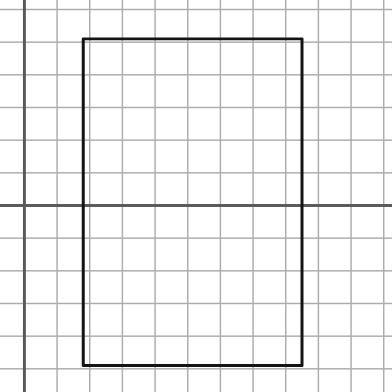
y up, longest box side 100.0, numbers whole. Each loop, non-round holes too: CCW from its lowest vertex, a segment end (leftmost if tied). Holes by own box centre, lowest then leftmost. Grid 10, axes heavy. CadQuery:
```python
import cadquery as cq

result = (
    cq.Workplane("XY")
    .moveTo(18.0, -49.0)
    .lineTo(85.0, -49.0)
    .lineTo(85.0, 51.0)
    .lineTo(18.0, 51.0)
    .close()
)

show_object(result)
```